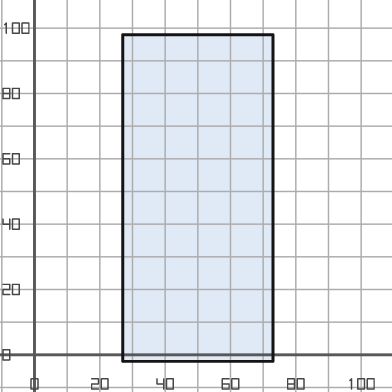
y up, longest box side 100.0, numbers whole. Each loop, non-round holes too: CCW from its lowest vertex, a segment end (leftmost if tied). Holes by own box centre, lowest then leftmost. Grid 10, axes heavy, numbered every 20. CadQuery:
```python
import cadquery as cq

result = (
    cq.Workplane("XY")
    .moveTo(27.0, -2.0)
    .lineTo(73.0, -2.0)
    .lineTo(73.0, 98.0)
    .lineTo(27.0, 98.0)
    .close()
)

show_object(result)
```